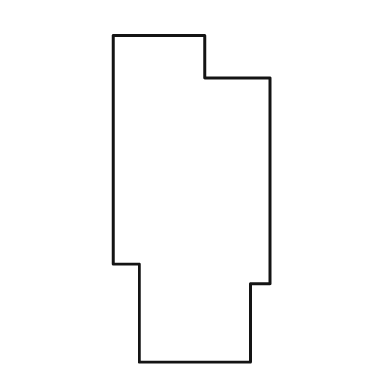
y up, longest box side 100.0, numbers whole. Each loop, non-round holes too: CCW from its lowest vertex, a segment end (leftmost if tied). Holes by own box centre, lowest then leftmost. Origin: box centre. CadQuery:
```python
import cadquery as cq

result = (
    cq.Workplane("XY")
    .moveTo(-16.0, -50.0)
    .lineTo(18.0, -50.0)
    .lineTo(18.0, -26.0)
    .lineTo(24.0, -26.0)
    .lineTo(24.0, 37.0)
    .lineTo(4.0, 37.0)
    .lineTo(4.0, 50.0)
    .lineTo(-24.0, 50.0)
    .lineTo(-24.0, -20.0)
    .lineTo(-16.0, -20.0)
    .close()
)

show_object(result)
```